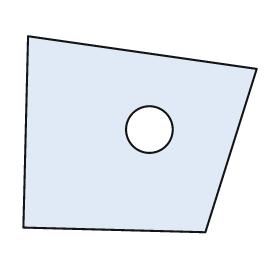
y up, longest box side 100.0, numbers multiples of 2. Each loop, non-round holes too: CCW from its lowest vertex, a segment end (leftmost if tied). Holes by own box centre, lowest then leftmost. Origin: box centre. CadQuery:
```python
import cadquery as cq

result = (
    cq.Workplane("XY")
    .moveTo(28.0, -42.0)
    .lineTo(50.0, 28.0)
    .lineTo(-48.0, 42.0)
    .lineTo(-50.0, -40.0)
    .close()
    .moveTo(4.0, 2.0)
    .circle(10.0)
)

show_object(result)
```